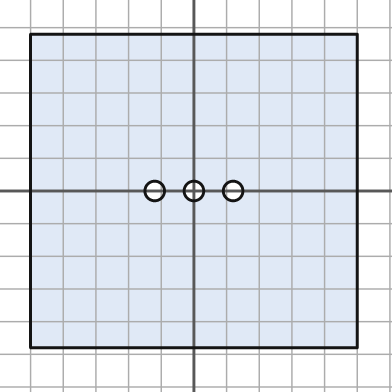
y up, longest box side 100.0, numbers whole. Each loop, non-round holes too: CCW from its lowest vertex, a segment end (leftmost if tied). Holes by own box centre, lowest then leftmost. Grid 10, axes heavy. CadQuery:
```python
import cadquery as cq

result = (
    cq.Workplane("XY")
    .moveTo(-50.0, -48.0)
    .lineTo(50.0, -48.0)
    .lineTo(50.0, 48.0)
    .lineTo(-50.0, 48.0)
    .close()
    .moveTo(-12.0, 0.0)
    .circle(3.0)
    .moveTo(0.0, 0.0)
    .circle(3.0)
    .moveTo(12.0, 0.0)
    .circle(3.0)
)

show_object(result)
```